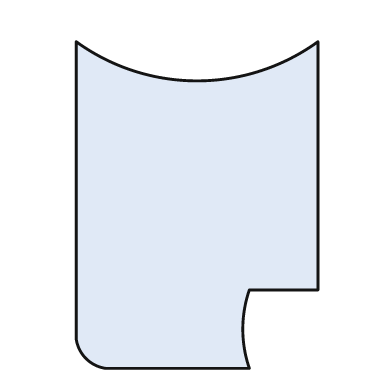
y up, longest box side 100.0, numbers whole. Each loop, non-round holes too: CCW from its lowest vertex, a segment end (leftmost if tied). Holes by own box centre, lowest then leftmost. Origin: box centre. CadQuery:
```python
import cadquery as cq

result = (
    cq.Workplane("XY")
    .moveTo(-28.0, -50.0)
    .lineTo(16.0, -50.0)
    .threePointArc((14.0, -38.0), (16.0, -26.0))
    .lineTo(37.0, -26.0)
    .lineTo(37.0, 50.0)
    .threePointArc((0.0, 38.0), (-37.0, 50.0))
    .lineTo(-37.0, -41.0)
    .threePointArc((-34.0, -47.0), (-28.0, -50.0))
    .close()
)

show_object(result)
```